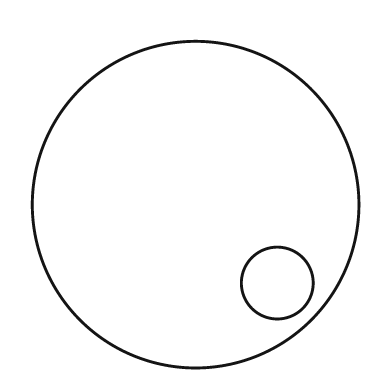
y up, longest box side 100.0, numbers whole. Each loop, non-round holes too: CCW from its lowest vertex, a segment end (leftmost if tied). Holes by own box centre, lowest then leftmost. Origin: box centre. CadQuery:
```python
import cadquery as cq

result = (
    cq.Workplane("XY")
    .moveTo(0.0, 0.0)
    .circle(50.0)
    .moveTo(25.0, -24.0)
    .circle(11.0)
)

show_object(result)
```